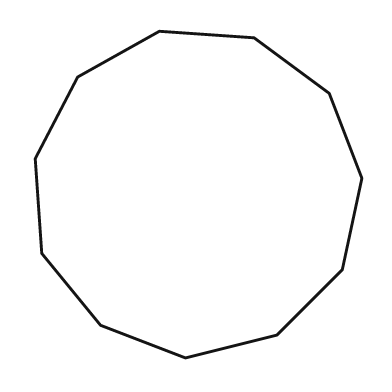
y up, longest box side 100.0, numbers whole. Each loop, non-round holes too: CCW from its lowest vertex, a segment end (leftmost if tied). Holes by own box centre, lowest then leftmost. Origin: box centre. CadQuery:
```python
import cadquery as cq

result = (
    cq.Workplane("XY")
    .moveTo(-4.0, -50.0)
    .lineTo(24.0, -43.0)
    .lineTo(44.0, -23.0)
    .lineTo(50.0, 5.0)
    .lineTo(40.0, 31.0)
    .lineTo(17.0, 48.0)
    .lineTo(-12.0, 50.0)
    .lineTo(-37.0, 36.0)
    .lineTo(-50.0, 11.0)
    .lineTo(-48.0, -18.0)
    .lineTo(-30.0, -40.0)
    .close()
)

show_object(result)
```